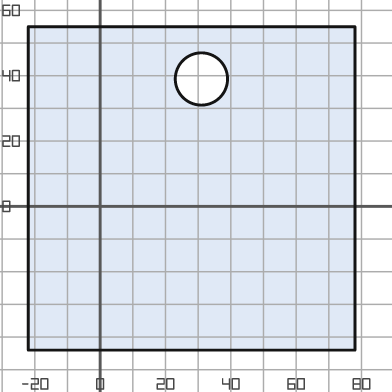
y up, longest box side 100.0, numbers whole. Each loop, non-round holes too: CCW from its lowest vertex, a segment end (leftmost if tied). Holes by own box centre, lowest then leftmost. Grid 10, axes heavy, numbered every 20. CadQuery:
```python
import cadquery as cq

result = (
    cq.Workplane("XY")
    .moveTo(-22.0, -44.0)
    .lineTo(78.0, -44.0)
    .lineTo(78.0, 55.0)
    .lineTo(-22.0, 55.0)
    .close()
    .moveTo(31.0, 39.0)
    .circle(8.0)
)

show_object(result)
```